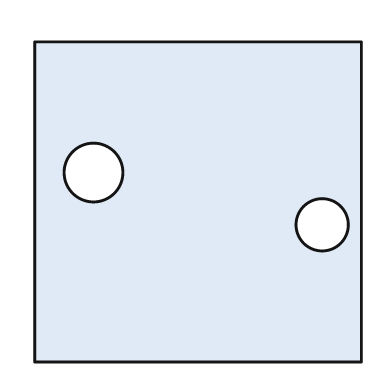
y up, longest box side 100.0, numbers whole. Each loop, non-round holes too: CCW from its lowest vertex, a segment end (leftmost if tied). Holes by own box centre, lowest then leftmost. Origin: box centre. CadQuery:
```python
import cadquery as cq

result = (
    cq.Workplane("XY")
    .moveTo(-50.0, -49.0)
    .lineTo(50.0, -49.0)
    .lineTo(50.0, 49.0)
    .lineTo(-50.0, 49.0)
    .close()
    .moveTo(38.0, -7.0)
    .circle(8.0)
    .moveTo(-32.0, 9.0)
    .circle(9.0)
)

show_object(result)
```